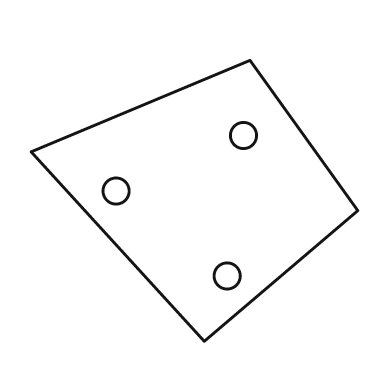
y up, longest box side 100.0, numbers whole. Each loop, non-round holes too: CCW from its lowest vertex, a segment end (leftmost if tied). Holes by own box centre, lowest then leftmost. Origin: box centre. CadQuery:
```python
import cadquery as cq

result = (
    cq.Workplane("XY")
    .moveTo(3.0, -43.0)
    .lineTo(50.0, -3.0)
    .lineTo(17.0, 43.0)
    .lineTo(-50.0, 15.0)
    .close()
    .moveTo(10.0, -23.0)
    .circle(4.0)
    .moveTo(-24.0, 3.0)
    .circle(4.0)
    .moveTo(15.0, 20.0)
    .circle(4.0)
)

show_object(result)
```